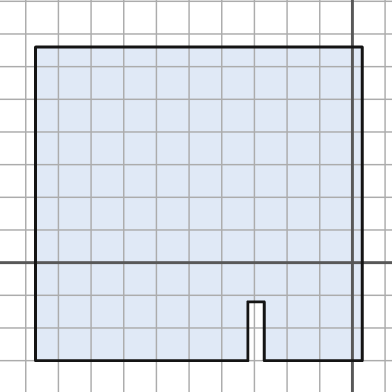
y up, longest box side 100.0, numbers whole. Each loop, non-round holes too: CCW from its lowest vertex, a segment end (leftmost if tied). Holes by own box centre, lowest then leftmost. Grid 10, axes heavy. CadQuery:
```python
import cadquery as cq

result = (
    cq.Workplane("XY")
    .moveTo(-97.0, -30.0)
    .lineTo(-32.0, -30.0)
    .lineTo(-32.0, -12.0)
    .lineTo(-27.0, -12.0)
    .lineTo(-27.0, -30.0)
    .lineTo(3.0, -30.0)
    .lineTo(3.0, 66.0)
    .lineTo(-97.0, 66.0)
    .close()
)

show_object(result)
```